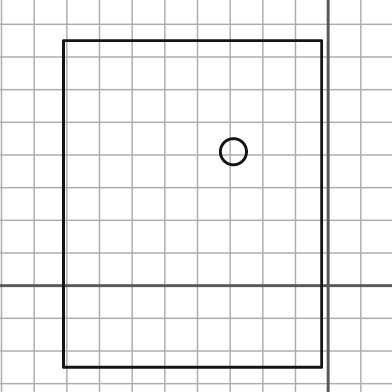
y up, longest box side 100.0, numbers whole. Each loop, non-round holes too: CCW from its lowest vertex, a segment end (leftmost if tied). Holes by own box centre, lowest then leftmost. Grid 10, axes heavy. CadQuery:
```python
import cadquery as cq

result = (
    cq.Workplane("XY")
    .moveTo(-81.0, -25.0)
    .lineTo(-2.0, -25.0)
    .lineTo(-2.0, 75.0)
    .lineTo(-81.0, 75.0)
    .close()
    .moveTo(-29.0, 41.0)
    .circle(4.0)
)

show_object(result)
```